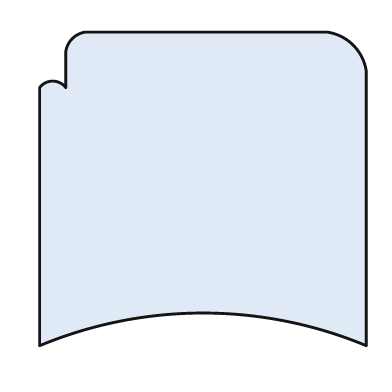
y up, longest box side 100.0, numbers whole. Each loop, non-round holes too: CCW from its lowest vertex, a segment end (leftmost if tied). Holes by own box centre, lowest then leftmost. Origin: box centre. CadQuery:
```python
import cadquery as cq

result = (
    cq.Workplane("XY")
    .moveTo(-50.0, -48.0)
    .threePointArc((0.0, -38.0), (50.0, -48.0))
    .lineTo(50.0, 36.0)
    .threePointArc((46.0, 44.0), (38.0, 48.0))
    .lineTo(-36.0, 48.0)
    .threePointArc((-40.0, 46.0), (-42.0, 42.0))
    .lineTo(-42.0, 31.0)
    .threePointArc((-46.0, 33.0), (-50.0, 31.0))
    .close()
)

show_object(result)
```